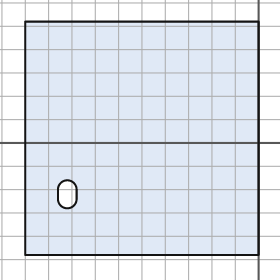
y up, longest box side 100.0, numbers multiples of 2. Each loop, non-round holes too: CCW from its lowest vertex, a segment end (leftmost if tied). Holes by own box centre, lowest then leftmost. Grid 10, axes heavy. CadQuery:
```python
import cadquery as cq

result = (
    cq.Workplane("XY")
    .moveTo(-100.0, -48.0)
    .lineTo(0.0, -48.0)
    .lineTo(0.0, 52.0)
    .lineTo(-100.0, 52.0)
    .close()
    .moveTo(-86.0, -24.0)
    .threePointArc((-82.0, -28.0), (-78.0, -24.0))
    .lineTo(-78.0, -20.0)
    .threePointArc((-82.0, -16.0), (-86.0, -20.0))
    .close()
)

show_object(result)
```